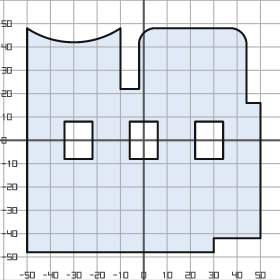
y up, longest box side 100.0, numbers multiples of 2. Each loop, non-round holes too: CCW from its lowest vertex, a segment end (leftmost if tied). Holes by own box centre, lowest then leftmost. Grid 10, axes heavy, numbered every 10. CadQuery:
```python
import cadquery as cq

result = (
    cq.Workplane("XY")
    .moveTo(-50.0, -48.0)
    .lineTo(30.0, -48.0)
    .lineTo(30.0, -42.0)
    .lineTo(50.0, -42.0)
    .lineTo(50.0, 16.0)
    .lineTo(44.0, 16.0)
    .lineTo(44.0, 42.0)
    .threePointArc((42.0, 46.0), (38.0, 48.0))
    .lineTo(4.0, 48.0)
    .threePointArc((0.0, 46.0), (-2.0, 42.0))
    .lineTo(-2.0, 22.0)
    .lineTo(-10.0, 22.0)
    .lineTo(-10.0, 48.0)
    .threePointArc((-30.0, 42.0), (-50.0, 48.0))
    .close()
    .moveTo(-34.0, -8.0)
    .lineTo(-22.0, -8.0)
    .lineTo(-22.0, 8.0)
    .lineTo(-34.0, 8.0)
    .close()
    .moveTo(-6.0, -8.0)
    .lineTo(6.0, -8.0)
    .lineTo(6.0, 8.0)
    .lineTo(-6.0, 8.0)
    .close()
    .moveTo(22.0, -8.0)
    .lineTo(34.0, -8.0)
    .lineTo(34.0, 8.0)
    .lineTo(22.0, 8.0)
    .close()
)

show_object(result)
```